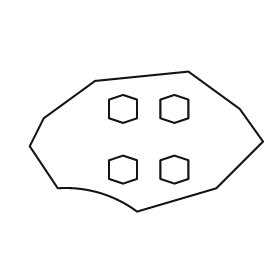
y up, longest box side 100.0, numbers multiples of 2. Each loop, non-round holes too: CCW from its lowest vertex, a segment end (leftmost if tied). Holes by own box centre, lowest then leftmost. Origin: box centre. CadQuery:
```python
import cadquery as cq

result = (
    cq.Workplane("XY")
    .moveTo(-4.0, -30.0)
    .lineTo(30.0, -20.0)
    .lineTo(50.0, 0.0)
    .lineTo(40.0, 14.0)
    .lineTo(18.0, 30.0)
    .lineTo(-22.0, 26.0)
    .lineTo(-44.0, 10.0)
    .lineTo(-50.0, -2.0)
    .lineTo(-38.0, -20.0)
    .threePointArc((-20.0, -22.0), (-4.0, -30.0))
    .close()
    .moveTo(-10.0, -18.0)
    .lineTo(-4.0, -16.0)
    .lineTo(-4.0, -8.0)
    .lineTo(-10.0, -6.0)
    .lineTo(-16.0, -8.0)
    .lineTo(-16.0, -16.0)
    .close()
    .moveTo(12.0, -18.0)
    .lineTo(18.0, -16.0)
    .lineTo(18.0, -8.0)
    .lineTo(12.0, -6.0)
    .lineTo(6.0, -8.0)
    .lineTo(6.0, -16.0)
    .close()
    .moveTo(-10.0, 8.0)
    .lineTo(-4.0, 10.0)
    .lineTo(-4.0, 18.0)
    .lineTo(-10.0, 20.0)
    .lineTo(-16.0, 18.0)
    .lineTo(-16.0, 10.0)
    .close()
    .moveTo(12.0, 8.0)
    .lineTo(18.0, 10.0)
    .lineTo(18.0, 18.0)
    .lineTo(12.0, 20.0)
    .lineTo(6.0, 18.0)
    .lineTo(6.0, 10.0)
    .close()
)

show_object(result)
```